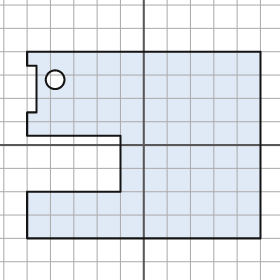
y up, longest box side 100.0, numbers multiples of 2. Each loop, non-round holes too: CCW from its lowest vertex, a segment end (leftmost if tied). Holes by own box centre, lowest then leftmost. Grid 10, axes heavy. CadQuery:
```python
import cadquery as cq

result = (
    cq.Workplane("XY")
    .moveTo(-50.0, -40.0)
    .lineTo(50.0, -40.0)
    .lineTo(50.0, 40.0)
    .lineTo(-50.0, 40.0)
    .lineTo(-50.0, 34.0)
    .lineTo(-46.0, 34.0)
    .lineTo(-46.0, 14.0)
    .lineTo(-50.0, 14.0)
    .lineTo(-50.0, 4.0)
    .lineTo(-10.0, 4.0)
    .lineTo(-10.0, -20.0)
    .lineTo(-50.0, -20.0)
    .close()
    .moveTo(-38.0, 28.0)
    .circle(4.0)
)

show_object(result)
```